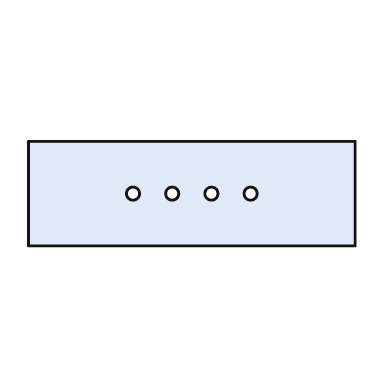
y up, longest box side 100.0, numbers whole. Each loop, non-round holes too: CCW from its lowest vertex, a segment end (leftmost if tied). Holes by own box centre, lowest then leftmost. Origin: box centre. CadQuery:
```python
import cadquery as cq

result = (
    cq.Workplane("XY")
    .moveTo(-50.0, -16.0)
    .lineTo(50.0, -16.0)
    .lineTo(50.0, 16.0)
    .lineTo(-50.0, 16.0)
    .close()
    .moveTo(-18.0, 0.0)
    .circle(2.0)
    .moveTo(-6.0, 0.0)
    .circle(2.0)
    .moveTo(6.0, 0.0)
    .circle(2.0)
    .moveTo(18.0, 0.0)
    .circle(2.0)
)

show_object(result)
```